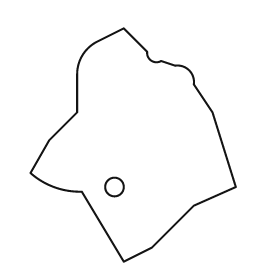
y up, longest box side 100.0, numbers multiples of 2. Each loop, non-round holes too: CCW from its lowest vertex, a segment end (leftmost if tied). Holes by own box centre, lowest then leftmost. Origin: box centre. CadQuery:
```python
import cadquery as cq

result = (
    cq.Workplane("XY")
    .moveTo(-4.0, -50.0)
    .lineTo(8.0, -44.0)
    .lineTo(26.0, -26.0)
    .lineTo(44.0, -18.0)
    .lineTo(34.0, 14.0)
    .lineTo(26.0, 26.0)
    .threePointArc((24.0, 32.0), (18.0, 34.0))
    .lineTo(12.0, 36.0)
    .threePointArc((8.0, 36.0), (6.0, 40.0))
    .lineTo(-4.0, 50.0)
    .lineTo(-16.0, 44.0)
    .threePointArc((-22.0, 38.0), (-24.0, 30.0))
    .lineTo(-24.0, 14.0)
    .lineTo(-36.0, 2.0)
    .lineTo(-44.0, -12.0)
    .threePointArc((-34.0, -18.0), (-22.0, -20.0))
    .close()
    .moveTo(-8.0, -18.0)
    .circle(4.0)
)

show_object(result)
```